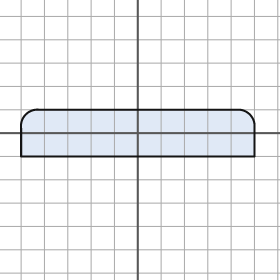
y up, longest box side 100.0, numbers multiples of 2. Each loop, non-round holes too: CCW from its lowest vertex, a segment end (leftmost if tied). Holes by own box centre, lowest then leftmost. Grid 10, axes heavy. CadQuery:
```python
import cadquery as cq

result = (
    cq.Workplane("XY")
    .moveTo(-50.0, -10.0)
    .lineTo(50.0, -10.0)
    .lineTo(50.0, 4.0)
    .threePointArc((48.0, 8.0), (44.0, 10.0))
    .lineTo(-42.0, 10.0)
    .threePointArc((-48.0, 8.0), (-50.0, 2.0))
    .close()
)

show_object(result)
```